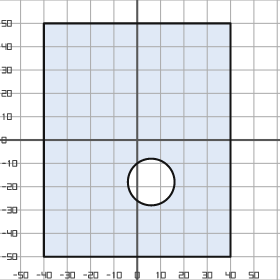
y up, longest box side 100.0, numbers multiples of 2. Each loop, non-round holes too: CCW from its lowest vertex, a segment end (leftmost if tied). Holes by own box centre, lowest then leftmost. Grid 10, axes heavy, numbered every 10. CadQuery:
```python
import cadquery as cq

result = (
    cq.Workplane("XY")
    .moveTo(-40.0, -50.0)
    .lineTo(40.0, -50.0)
    .lineTo(40.0, 50.0)
    .lineTo(-40.0, 50.0)
    .close()
    .moveTo(6.0, -18.0)
    .circle(10.0)
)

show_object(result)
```